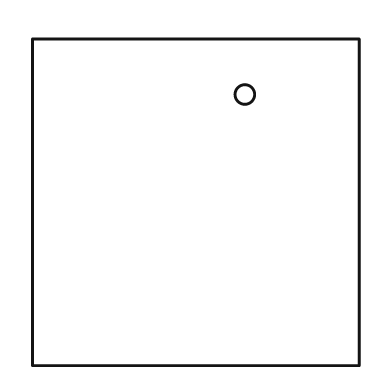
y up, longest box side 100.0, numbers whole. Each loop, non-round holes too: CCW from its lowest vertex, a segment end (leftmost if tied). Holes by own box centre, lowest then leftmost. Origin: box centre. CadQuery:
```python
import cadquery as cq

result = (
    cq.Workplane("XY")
    .moveTo(-50.0, -50.0)
    .lineTo(50.0, -50.0)
    .lineTo(50.0, 50.0)
    .lineTo(-50.0, 50.0)
    .close()
    .moveTo(15.0, 33.0)
    .circle(3.0)
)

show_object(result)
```